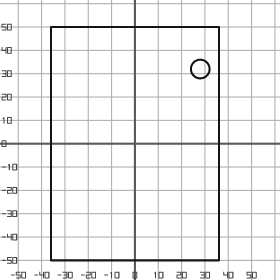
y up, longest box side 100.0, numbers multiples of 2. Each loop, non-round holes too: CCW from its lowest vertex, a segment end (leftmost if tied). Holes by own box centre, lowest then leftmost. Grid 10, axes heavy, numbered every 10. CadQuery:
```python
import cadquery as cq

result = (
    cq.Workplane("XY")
    .moveTo(-36.0, -50.0)
    .lineTo(36.0, -50.0)
    .lineTo(36.0, 50.0)
    .lineTo(-36.0, 50.0)
    .close()
    .moveTo(28.0, 32.0)
    .circle(4.0)
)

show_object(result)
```